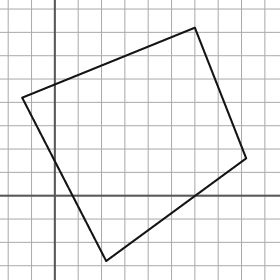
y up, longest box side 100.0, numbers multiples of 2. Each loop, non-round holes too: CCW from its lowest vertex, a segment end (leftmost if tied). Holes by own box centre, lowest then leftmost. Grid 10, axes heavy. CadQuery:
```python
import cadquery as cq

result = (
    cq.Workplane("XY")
    .moveTo(22.0, -28.0)
    .lineTo(82.0, 16.0)
    .lineTo(60.0, 72.0)
    .lineTo(-14.0, 42.0)
    .close()
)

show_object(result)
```